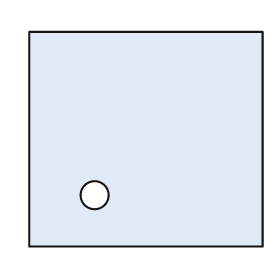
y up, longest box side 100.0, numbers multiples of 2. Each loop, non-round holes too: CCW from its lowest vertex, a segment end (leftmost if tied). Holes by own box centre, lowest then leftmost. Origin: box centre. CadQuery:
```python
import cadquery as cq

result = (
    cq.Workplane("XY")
    .moveTo(-50.0, -46.0)
    .lineTo(50.0, -46.0)
    .lineTo(50.0, 46.0)
    .lineTo(-50.0, 46.0)
    .close()
    .moveTo(-22.0, -24.0)
    .circle(6.0)
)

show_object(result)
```